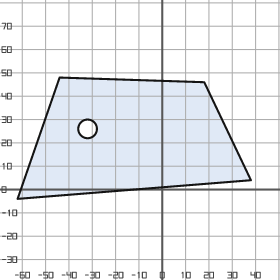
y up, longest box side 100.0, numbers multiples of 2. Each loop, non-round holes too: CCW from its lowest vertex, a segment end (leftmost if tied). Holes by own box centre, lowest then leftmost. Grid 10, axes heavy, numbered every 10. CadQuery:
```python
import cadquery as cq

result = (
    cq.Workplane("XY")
    .moveTo(-62.0, -4.0)
    .lineTo(38.0, 4.0)
    .lineTo(18.0, 46.0)
    .lineTo(-44.0, 48.0)
    .close()
    .moveTo(-32.0, 26.0)
    .circle(4.0)
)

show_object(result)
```